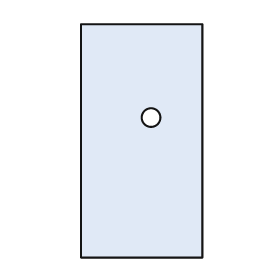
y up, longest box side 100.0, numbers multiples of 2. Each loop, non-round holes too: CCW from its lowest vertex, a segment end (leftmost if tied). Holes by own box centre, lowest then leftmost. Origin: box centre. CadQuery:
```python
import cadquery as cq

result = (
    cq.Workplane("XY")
    .moveTo(-26.0, -50.0)
    .lineTo(26.0, -50.0)
    .lineTo(26.0, 50.0)
    .lineTo(-26.0, 50.0)
    .close()
    .moveTo(4.0, 10.0)
    .circle(4.0)
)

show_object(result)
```